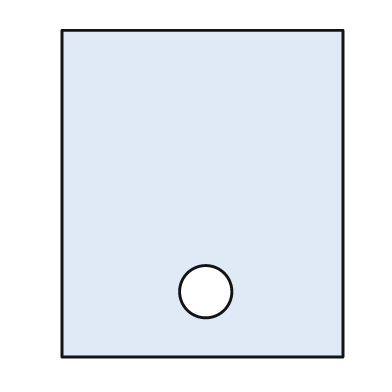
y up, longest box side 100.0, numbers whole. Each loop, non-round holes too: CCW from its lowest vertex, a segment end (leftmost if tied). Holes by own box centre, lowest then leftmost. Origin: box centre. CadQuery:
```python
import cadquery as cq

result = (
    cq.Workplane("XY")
    .moveTo(-43.0, -50.0)
    .lineTo(43.0, -50.0)
    .lineTo(43.0, 50.0)
    .lineTo(-43.0, 50.0)
    .close()
    .moveTo(1.0, -30.0)
    .circle(8.0)
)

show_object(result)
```